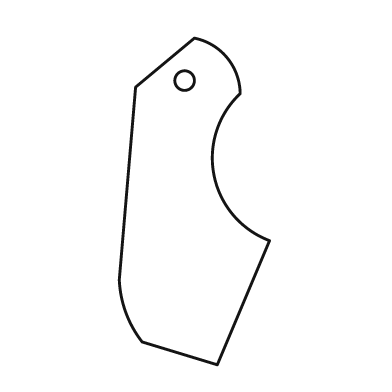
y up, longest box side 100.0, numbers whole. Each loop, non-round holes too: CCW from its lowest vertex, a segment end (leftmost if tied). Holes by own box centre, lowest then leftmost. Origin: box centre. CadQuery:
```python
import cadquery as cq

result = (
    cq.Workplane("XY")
    .moveTo(7.0, -50.0)
    .lineTo(23.0, -12.0)
    .threePointArc((6.0, 8.0), (14.0, 33.0))
    .threePointArc((10.0, 44.0), (0.0, 50.0))
    .lineTo(-18.0, 35.0)
    .lineTo(-23.0, -24.0)
    .threePointArc((-21.0, -34.0), (-16.0, -43.0))
    .close()
    .moveTo(-3.0, 37.0)
    .circle(3.0)
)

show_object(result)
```